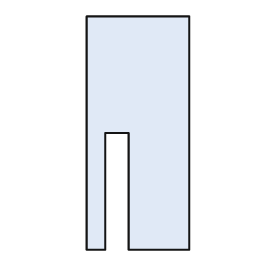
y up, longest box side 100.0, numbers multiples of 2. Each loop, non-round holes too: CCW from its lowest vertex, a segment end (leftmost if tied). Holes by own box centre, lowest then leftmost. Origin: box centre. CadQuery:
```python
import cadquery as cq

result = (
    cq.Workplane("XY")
    .moveTo(-22.0, -50.0)
    .lineTo(-14.0, -50.0)
    .lineTo(-14.0, 0.0)
    .lineTo(-4.0, 0.0)
    .lineTo(-4.0, -50.0)
    .lineTo(22.0, -50.0)
    .lineTo(22.0, 50.0)
    .lineTo(-22.0, 50.0)
    .close()
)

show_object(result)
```